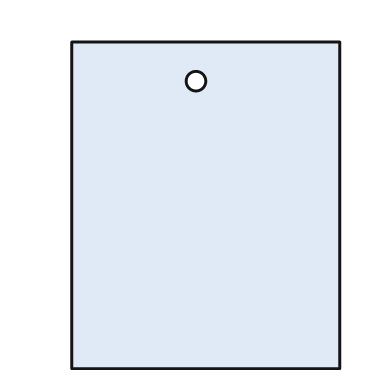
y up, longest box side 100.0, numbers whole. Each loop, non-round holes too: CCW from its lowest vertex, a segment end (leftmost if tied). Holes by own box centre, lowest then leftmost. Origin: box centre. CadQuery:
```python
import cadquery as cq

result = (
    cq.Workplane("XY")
    .moveTo(-41.0, -50.0)
    .lineTo(41.0, -50.0)
    .lineTo(41.0, 50.0)
    .lineTo(-41.0, 50.0)
    .close()
    .moveTo(-3.0, 38.0)
    .circle(3.0)
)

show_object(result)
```